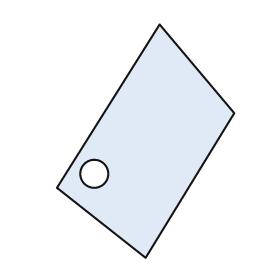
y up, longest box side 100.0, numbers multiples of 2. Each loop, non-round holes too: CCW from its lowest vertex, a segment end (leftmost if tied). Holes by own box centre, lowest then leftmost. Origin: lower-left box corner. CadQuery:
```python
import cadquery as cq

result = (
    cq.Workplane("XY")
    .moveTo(38.0, 0.0)
    .lineTo(76.0, 62.0)
    .lineTo(44.0, 100.0)
    .lineTo(0.0, 30.0)
    .close()
    .moveTo(16.0, 36.0)
    .circle(6.0)
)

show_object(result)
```